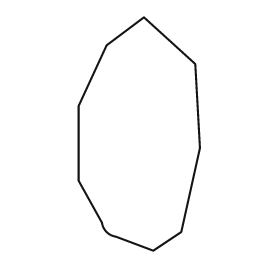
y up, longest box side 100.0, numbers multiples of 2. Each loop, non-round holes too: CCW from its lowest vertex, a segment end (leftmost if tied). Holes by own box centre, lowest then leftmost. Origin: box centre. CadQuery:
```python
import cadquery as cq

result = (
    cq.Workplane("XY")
    .moveTo(6.0, -50.0)
    .lineTo(18.0, -42.0)
    .lineTo(26.0, -6.0)
    .lineTo(24.0, 30.0)
    .lineTo(2.0, 50.0)
    .lineTo(-14.0, 38.0)
    .lineTo(-26.0, 12.0)
    .lineTo(-26.0, -20.0)
    .lineTo(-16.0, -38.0)
    .threePointArc((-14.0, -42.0), (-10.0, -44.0))
    .close()
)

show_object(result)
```